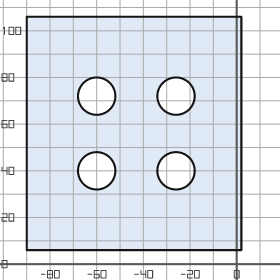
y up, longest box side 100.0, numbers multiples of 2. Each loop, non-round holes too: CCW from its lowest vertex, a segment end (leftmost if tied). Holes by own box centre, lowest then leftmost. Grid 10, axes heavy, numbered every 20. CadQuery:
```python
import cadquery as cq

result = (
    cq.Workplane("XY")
    .moveTo(-90.0, 6.0)
    .lineTo(2.0, 6.0)
    .lineTo(2.0, 106.0)
    .lineTo(-90.0, 106.0)
    .close()
    .moveTo(-60.0, 40.0)
    .circle(8.0)
    .moveTo(-26.0, 40.0)
    .circle(8.0)
    .moveTo(-60.0, 72.0)
    .circle(8.0)
    .moveTo(-26.0, 72.0)
    .circle(8.0)
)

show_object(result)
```